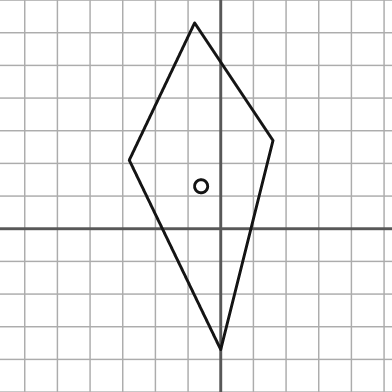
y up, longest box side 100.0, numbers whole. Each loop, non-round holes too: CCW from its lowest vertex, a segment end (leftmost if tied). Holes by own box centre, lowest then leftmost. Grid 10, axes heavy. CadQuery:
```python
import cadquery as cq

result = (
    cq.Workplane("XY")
    .moveTo(0.0, -37.0)
    .lineTo(16.0, 27.0)
    .lineTo(-8.0, 63.0)
    .lineTo(-28.0, 21.0)
    .close()
    .moveTo(-6.0, 13.0)
    .circle(2.0)
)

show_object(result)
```